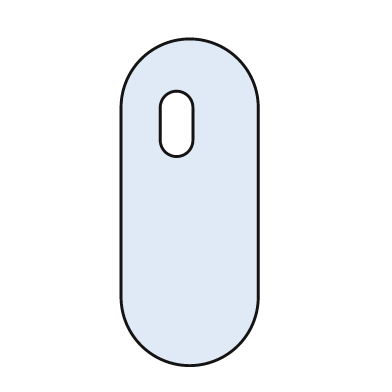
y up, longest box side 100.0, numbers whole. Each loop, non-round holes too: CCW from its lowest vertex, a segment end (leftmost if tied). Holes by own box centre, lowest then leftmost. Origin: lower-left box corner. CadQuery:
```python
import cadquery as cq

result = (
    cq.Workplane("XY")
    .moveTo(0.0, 21.0)
    .threePointArc((21.0, 0.0), (42.0, 21.0))
    .lineTo(42.0, 79.0)
    .threePointArc((21.0, 100.0), (0.0, 79.0))
    .close()
    .moveTo(12.0, 69.0)
    .threePointArc((17.0, 64.0), (22.0, 69.0))
    .lineTo(22.0, 79.0)
    .threePointArc((17.0, 84.0), (12.0, 79.0))
    .close()
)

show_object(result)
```